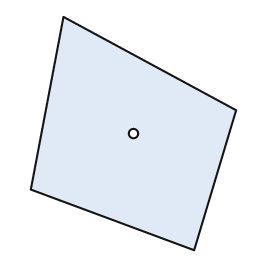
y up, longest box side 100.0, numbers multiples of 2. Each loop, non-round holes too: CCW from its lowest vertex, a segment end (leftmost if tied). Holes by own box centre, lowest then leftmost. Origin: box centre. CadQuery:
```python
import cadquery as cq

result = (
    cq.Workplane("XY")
    .moveTo(26.0, -50.0)
    .lineTo(44.0, 10.0)
    .lineTo(-30.0, 50.0)
    .lineTo(-44.0, -24.0)
    .close()
    .moveTo(0.0, 0.0)
    .circle(2.0)
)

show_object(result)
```